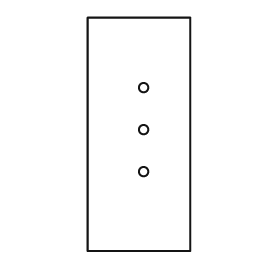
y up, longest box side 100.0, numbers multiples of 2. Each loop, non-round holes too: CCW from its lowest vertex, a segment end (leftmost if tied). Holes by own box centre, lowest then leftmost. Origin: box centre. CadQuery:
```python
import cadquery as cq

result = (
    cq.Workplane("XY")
    .moveTo(-22.0, -50.0)
    .lineTo(22.0, -50.0)
    .lineTo(22.0, 50.0)
    .lineTo(-22.0, 50.0)
    .close()
    .moveTo(2.0, -16.0)
    .circle(2.0)
    .moveTo(2.0, 2.0)
    .circle(2.0)
    .moveTo(2.0, 20.0)
    .circle(2.0)
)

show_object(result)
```